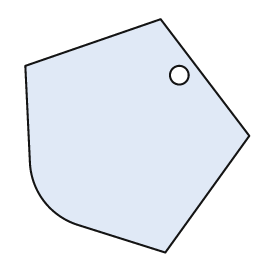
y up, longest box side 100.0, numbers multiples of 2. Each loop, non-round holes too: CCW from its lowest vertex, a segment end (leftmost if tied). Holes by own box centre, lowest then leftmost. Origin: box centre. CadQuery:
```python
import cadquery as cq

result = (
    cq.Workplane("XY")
    .moveTo(12.0, -50.0)
    .lineTo(48.0, 0.0)
    .lineTo(10.0, 50.0)
    .lineTo(-48.0, 30.0)
    .lineTo(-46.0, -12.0)
    .threePointArc((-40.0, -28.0), (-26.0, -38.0))
    .close()
    .moveTo(18.0, 26.0)
    .circle(4.0)
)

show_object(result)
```